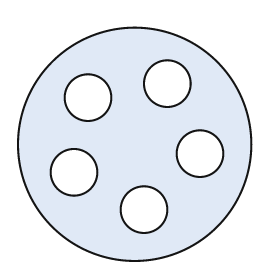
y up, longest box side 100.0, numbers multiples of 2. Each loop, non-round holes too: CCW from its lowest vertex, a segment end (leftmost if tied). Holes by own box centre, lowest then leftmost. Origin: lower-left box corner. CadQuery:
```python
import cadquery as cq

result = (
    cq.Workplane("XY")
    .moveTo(50.0, 50.0)
    .circle(50.0)
    .moveTo(54.0, 22.0)
    .circle(10.0)
    .moveTo(24.0, 38.0)
    .circle(10.0)
    .moveTo(78.0, 46.0)
    .circle(10.0)
    .moveTo(30.0, 70.0)
    .circle(10.0)
    .moveTo(64.0, 76.0)
    .circle(10.0)
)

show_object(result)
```